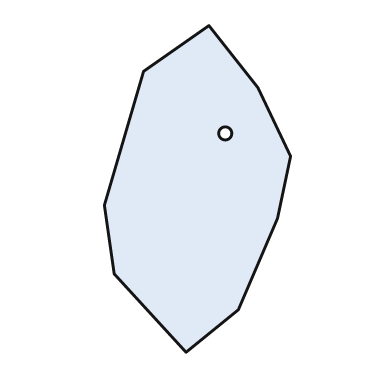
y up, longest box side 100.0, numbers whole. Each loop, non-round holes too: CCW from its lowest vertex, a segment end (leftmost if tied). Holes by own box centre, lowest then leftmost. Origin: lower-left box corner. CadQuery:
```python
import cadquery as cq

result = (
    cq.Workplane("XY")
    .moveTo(25.0, 0.0)
    .lineTo(41.0, 13.0)
    .lineTo(53.0, 41.0)
    .lineTo(57.0, 60.0)
    .lineTo(47.0, 81.0)
    .lineTo(32.0, 100.0)
    .lineTo(12.0, 86.0)
    .lineTo(0.0, 45.0)
    .lineTo(3.0, 24.0)
    .close()
    .moveTo(37.0, 67.0)
    .circle(2.0)
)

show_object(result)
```